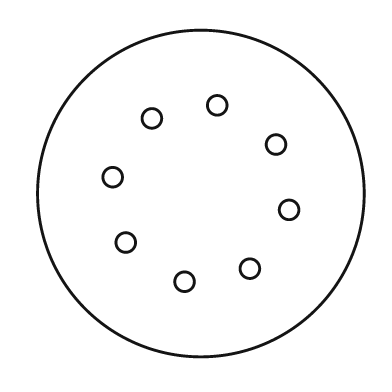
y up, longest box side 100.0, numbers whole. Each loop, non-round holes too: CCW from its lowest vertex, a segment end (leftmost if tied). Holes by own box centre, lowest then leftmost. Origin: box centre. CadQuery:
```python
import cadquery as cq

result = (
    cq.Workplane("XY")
    .moveTo(0.0, 0.0)
    .circle(50.0)
    .moveTo(-5.0, -27.0)
    .circle(3.0)
    .moveTo(15.0, -23.0)
    .circle(3.0)
    .moveTo(-23.0, -15.0)
    .circle(3.0)
    .moveTo(27.0, -5.0)
    .circle(3.0)
    .moveTo(-27.0, 5.0)
    .circle(3.0)
    .moveTo(23.0, 15.0)
    .circle(3.0)
    .moveTo(-15.0, 23.0)
    .circle(3.0)
    .moveTo(5.0, 27.0)
    .circle(3.0)
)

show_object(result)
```